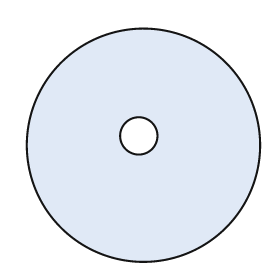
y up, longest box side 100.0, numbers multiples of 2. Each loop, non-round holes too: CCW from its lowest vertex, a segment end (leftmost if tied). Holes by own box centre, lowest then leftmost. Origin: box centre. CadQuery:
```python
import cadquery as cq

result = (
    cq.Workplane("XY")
    .moveTo(0.0, 0.0)
    .circle(50.0)
    .moveTo(-2.0, 4.0)
    .circle(8.0)
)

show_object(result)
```